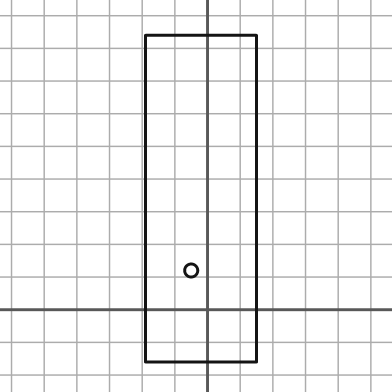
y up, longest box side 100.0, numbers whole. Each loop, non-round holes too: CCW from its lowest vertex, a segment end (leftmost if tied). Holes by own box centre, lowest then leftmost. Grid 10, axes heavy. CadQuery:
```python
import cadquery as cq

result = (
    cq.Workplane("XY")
    .moveTo(-19.0, -16.0)
    .lineTo(15.0, -16.0)
    .lineTo(15.0, 84.0)
    .lineTo(-19.0, 84.0)
    .close()
    .moveTo(-5.0, 12.0)
    .circle(2.0)
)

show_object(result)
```